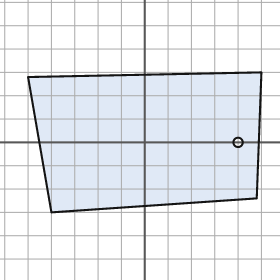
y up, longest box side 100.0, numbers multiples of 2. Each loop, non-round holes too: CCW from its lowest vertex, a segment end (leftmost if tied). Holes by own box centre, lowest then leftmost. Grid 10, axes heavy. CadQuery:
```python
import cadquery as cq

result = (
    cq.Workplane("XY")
    .moveTo(-40.0, -30.0)
    .lineTo(48.0, -24.0)
    .lineTo(50.0, 30.0)
    .lineTo(-50.0, 28.0)
    .close()
    .moveTo(40.0, 0.0)
    .circle(2.0)
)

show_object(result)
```